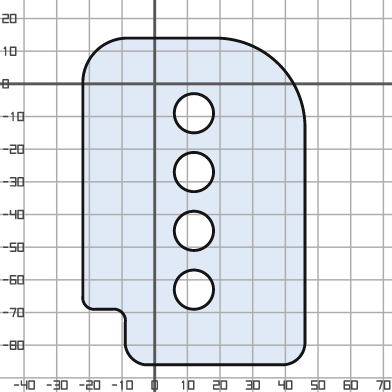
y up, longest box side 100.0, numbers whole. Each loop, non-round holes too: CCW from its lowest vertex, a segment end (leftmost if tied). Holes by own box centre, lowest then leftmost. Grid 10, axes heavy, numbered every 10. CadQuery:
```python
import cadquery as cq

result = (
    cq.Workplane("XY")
    .moveTo(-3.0, -86.0)
    .lineTo(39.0, -86.0)
    .threePointArc((44.0, -84.0), (46.0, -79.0))
    .lineTo(46.0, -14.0)
    .threePointArc((38.0, 6.0), (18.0, 14.0))
    .lineTo(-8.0, 14.0)
    .threePointArc((-18.0, 10.0), (-22.0, 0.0))
    .lineTo(-22.0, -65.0)
    .threePointArc((-21.0, -68.0), (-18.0, -69.0))
    .lineTo(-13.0, -69.0)
    .threePointArc((-10.0, -70.0), (-9.0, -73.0))
    .lineTo(-9.0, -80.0)
    .threePointArc((-7.0, -84.0), (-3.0, -86.0))
    .close()
    .moveTo(12.0, -63.0)
    .circle(6.0)
    .moveTo(12.0, -45.0)
    .circle(6.0)
    .moveTo(12.0, -27.0)
    .circle(6.0)
    .moveTo(12.0, -9.0)
    .circle(6.0)
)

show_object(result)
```